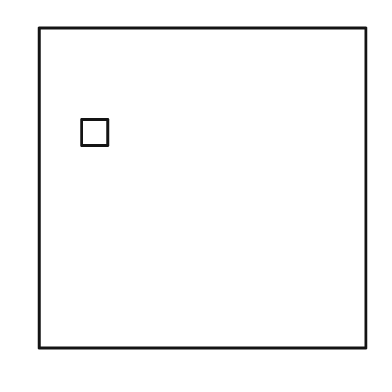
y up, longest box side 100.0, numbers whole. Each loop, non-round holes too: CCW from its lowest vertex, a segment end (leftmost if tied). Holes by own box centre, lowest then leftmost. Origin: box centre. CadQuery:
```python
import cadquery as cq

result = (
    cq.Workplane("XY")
    .moveTo(-50.0, -49.0)
    .lineTo(50.0, -49.0)
    .lineTo(50.0, 49.0)
    .lineTo(-50.0, 49.0)
    .close()
    .moveTo(-37.0, 13.0)
    .lineTo(-29.0, 13.0)
    .lineTo(-29.0, 21.0)
    .lineTo(-37.0, 21.0)
    .close()
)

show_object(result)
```